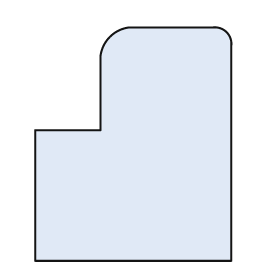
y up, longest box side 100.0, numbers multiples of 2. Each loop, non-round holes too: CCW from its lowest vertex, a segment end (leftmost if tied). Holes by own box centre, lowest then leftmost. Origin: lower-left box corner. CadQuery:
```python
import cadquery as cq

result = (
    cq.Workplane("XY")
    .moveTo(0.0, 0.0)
    .lineTo(84.0, 0.0)
    .lineTo(84.0, 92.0)
    .threePointArc((82.0, 98.0), (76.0, 100.0))
    .lineTo(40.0, 100.0)
    .threePointArc((32.0, 96.0), (28.0, 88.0))
    .lineTo(28.0, 56.0)
    .lineTo(0.0, 56.0)
    .close()
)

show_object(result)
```